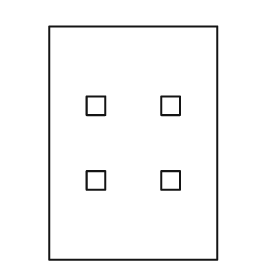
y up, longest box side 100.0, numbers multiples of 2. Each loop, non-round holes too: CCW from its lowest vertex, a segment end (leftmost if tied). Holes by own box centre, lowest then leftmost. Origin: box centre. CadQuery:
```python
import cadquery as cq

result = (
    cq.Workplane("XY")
    .moveTo(-36.0, -50.0)
    .lineTo(36.0, -50.0)
    .lineTo(36.0, 50.0)
    .lineTo(-36.0, 50.0)
    .close()
    .moveTo(-20.0, -20.0)
    .lineTo(-12.0, -20.0)
    .lineTo(-12.0, -12.0)
    .lineTo(-20.0, -12.0)
    .close()
    .moveTo(12.0, -20.0)
    .lineTo(20.0, -20.0)
    .lineTo(20.0, -12.0)
    .lineTo(12.0, -12.0)
    .close()
    .moveTo(-20.0, 12.0)
    .lineTo(-12.0, 12.0)
    .lineTo(-12.0, 20.0)
    .lineTo(-20.0, 20.0)
    .close()
    .moveTo(12.0, 12.0)
    .lineTo(20.0, 12.0)
    .lineTo(20.0, 20.0)
    .lineTo(12.0, 20.0)
    .close()
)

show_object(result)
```